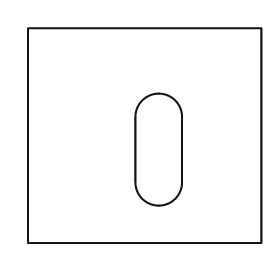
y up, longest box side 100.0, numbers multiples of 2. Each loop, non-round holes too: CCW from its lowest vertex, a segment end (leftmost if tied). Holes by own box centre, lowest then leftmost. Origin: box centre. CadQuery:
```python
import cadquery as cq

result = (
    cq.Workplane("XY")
    .moveTo(-50.0, -46.0)
    .lineTo(50.0, -46.0)
    .lineTo(50.0, 46.0)
    .lineTo(-50.0, 46.0)
    .close()
    .moveTo(-4.0, -20.0)
    .threePointArc((6.0, -30.0), (16.0, -20.0))
    .lineTo(16.0, 8.0)
    .threePointArc((6.0, 18.0), (-4.0, 8.0))
    .close()
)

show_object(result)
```